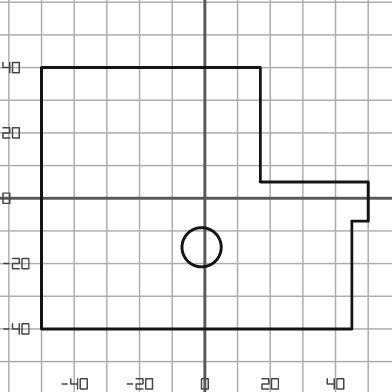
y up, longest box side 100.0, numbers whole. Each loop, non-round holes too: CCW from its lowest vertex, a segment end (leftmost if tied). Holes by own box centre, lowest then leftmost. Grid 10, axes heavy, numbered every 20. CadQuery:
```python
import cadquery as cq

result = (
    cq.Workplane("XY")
    .moveTo(-50.0, -40.0)
    .lineTo(45.0, -40.0)
    .lineTo(45.0, -7.0)
    .lineTo(50.0, -7.0)
    .lineTo(50.0, 5.0)
    .lineTo(17.0, 5.0)
    .lineTo(17.0, 40.0)
    .lineTo(-50.0, 40.0)
    .close()
    .moveTo(-1.0, -15.0)
    .circle(6.0)
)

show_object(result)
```